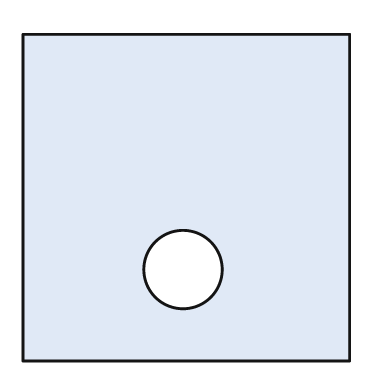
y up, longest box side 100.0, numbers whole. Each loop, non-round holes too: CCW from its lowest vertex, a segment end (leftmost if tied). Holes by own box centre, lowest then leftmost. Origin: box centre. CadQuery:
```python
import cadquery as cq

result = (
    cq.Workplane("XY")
    .moveTo(-50.0, -50.0)
    .lineTo(50.0, -50.0)
    .lineTo(50.0, 50.0)
    .lineTo(-50.0, 50.0)
    .close()
    .moveTo(-1.0, -22.0)
    .circle(12.0)
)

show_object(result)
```